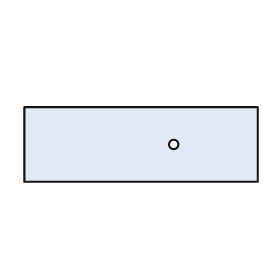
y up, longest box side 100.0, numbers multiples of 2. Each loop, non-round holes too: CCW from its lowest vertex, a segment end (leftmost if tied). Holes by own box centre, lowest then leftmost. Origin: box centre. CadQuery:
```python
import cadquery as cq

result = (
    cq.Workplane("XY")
    .moveTo(-50.0, -16.0)
    .lineTo(50.0, -16.0)
    .lineTo(50.0, 16.0)
    .lineTo(-50.0, 16.0)
    .close()
    .moveTo(14.0, 0.0)
    .circle(2.0)
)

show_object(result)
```